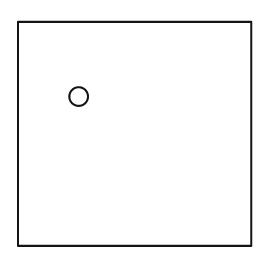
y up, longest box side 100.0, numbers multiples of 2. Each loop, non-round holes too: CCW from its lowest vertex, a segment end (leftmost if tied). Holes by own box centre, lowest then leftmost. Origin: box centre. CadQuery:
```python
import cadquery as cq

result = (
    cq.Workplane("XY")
    .moveTo(-50.0, -48.0)
    .lineTo(50.0, -48.0)
    .lineTo(50.0, 48.0)
    .lineTo(-50.0, 48.0)
    .close()
    .moveTo(-24.0, 16.0)
    .circle(4.0)
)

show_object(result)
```